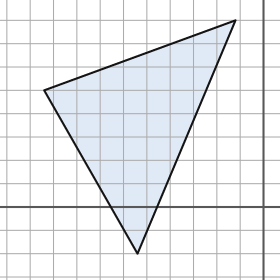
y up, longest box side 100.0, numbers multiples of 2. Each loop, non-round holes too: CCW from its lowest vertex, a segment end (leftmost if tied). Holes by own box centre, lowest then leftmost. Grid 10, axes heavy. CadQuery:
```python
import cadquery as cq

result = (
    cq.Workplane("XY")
    .moveTo(-54.0, -20.0)
    .lineTo(-12.0, 80.0)
    .lineTo(-94.0, 50.0)
    .close()
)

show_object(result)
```